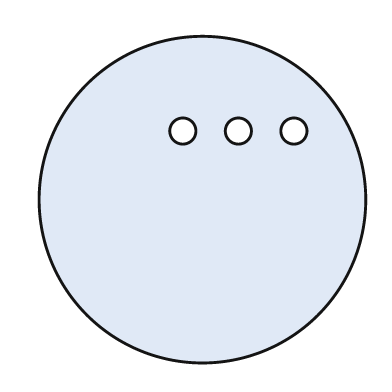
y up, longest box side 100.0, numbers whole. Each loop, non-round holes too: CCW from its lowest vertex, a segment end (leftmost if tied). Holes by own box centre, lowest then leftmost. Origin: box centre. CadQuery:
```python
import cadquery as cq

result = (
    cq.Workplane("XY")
    .moveTo(0.0, 0.0)
    .circle(50.0)
    .moveTo(-6.0, 21.0)
    .circle(4.0)
    .moveTo(11.0, 21.0)
    .circle(4.0)
    .moveTo(28.0, 21.0)
    .circle(4.0)
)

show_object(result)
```